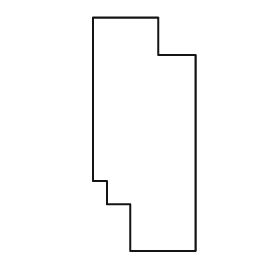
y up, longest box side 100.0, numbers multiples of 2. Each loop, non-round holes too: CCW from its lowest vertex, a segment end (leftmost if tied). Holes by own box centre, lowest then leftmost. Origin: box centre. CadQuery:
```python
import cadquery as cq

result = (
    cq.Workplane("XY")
    .moveTo(-6.0, -50.0)
    .lineTo(22.0, -50.0)
    .lineTo(22.0, 34.0)
    .lineTo(6.0, 34.0)
    .lineTo(6.0, 50.0)
    .lineTo(-22.0, 50.0)
    .lineTo(-22.0, -20.0)
    .lineTo(-16.0, -20.0)
    .lineTo(-16.0, -30.0)
    .lineTo(-6.0, -30.0)
    .close()
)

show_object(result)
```